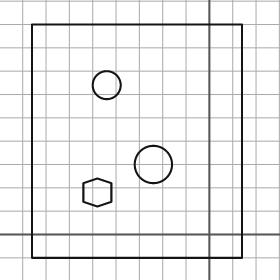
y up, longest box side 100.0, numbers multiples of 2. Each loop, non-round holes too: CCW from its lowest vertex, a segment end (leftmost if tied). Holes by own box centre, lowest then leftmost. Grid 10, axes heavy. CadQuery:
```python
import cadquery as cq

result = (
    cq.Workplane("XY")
    .moveTo(-76.0, -10.0)
    .lineTo(14.0, -10.0)
    .lineTo(14.0, 90.0)
    .lineTo(-76.0, 90.0)
    .close()
    .moveTo(-48.0, 12.0)
    .lineTo(-42.0, 14.0)
    .lineTo(-42.0, 22.0)
    .lineTo(-48.0, 24.0)
    .lineTo(-54.0, 22.0)
    .lineTo(-54.0, 14.0)
    .close()
    .moveTo(-24.0, 30.0)
    .circle(8.0)
    .moveTo(-44.0, 64.0)
    .circle(6.0)
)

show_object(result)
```